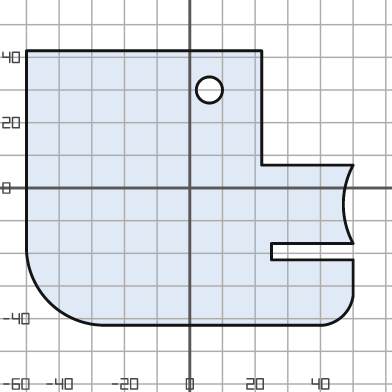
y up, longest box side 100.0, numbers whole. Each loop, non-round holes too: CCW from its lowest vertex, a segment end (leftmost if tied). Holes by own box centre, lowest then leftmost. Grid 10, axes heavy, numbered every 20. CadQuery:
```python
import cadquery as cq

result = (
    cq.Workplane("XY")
    .moveTo(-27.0, -42.0)
    .lineTo(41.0, -42.0)
    .threePointArc((47.0, -39.0), (50.0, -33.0))
    .lineTo(50.0, -22.0)
    .lineTo(25.0, -22.0)
    .lineTo(25.0, -17.0)
    .lineTo(50.0, -17.0)
    .threePointArc((47.0, -5.0), (50.0, 7.0))
    .lineTo(22.0, 7.0)
    .lineTo(22.0, 42.0)
    .lineTo(-50.0, 42.0)
    .lineTo(-50.0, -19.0)
    .threePointArc((-43.0, -35.0), (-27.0, -42.0))
    .close()
    .moveTo(6.0, 30.0)
    .circle(4.0)
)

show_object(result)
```